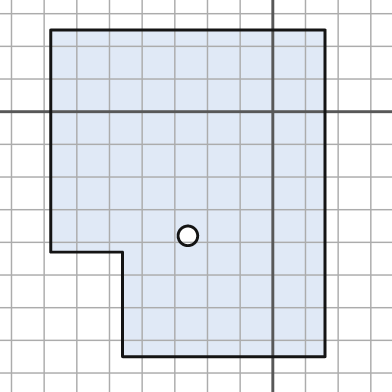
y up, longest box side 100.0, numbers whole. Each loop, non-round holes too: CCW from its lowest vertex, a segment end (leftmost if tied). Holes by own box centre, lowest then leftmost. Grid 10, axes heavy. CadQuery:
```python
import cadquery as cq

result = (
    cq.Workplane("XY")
    .moveTo(-46.0, -75.0)
    .lineTo(16.0, -75.0)
    .lineTo(16.0, 25.0)
    .lineTo(-68.0, 25.0)
    .lineTo(-68.0, -43.0)
    .lineTo(-46.0, -43.0)
    .close()
    .moveTo(-26.0, -38.0)
    .circle(3.0)
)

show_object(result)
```